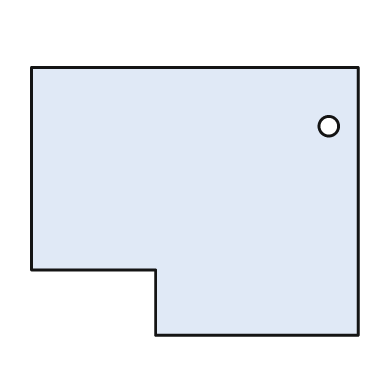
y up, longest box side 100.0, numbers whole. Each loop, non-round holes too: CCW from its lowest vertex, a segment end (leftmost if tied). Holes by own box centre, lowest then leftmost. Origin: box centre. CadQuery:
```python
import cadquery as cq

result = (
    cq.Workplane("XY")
    .moveTo(-12.0, -41.0)
    .lineTo(50.0, -41.0)
    .lineTo(50.0, 41.0)
    .lineTo(-50.0, 41.0)
    .lineTo(-50.0, -21.0)
    .lineTo(-12.0, -21.0)
    .close()
    .moveTo(41.0, 23.0)
    .circle(3.0)
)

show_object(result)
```